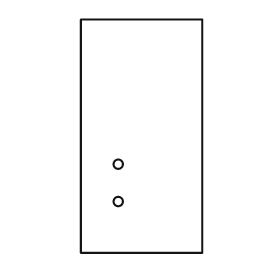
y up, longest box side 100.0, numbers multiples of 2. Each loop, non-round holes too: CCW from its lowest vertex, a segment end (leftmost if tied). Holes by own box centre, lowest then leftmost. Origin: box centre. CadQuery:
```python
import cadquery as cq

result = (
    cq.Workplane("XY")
    .moveTo(-26.0, -50.0)
    .lineTo(26.0, -50.0)
    .lineTo(26.0, 50.0)
    .lineTo(-26.0, 50.0)
    .close()
    .moveTo(-10.0, -28.0)
    .circle(2.0)
    .moveTo(-10.0, -12.0)
    .circle(2.0)
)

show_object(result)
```